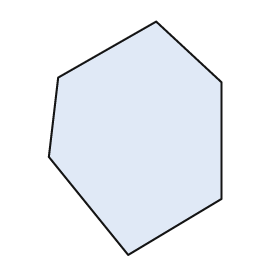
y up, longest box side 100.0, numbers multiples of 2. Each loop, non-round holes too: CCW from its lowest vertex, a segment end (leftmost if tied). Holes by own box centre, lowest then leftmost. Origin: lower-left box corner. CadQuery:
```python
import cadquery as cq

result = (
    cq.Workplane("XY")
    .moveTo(34.0, 0.0)
    .lineTo(74.0, 24.0)
    .lineTo(74.0, 74.0)
    .lineTo(46.0, 100.0)
    .lineTo(4.0, 76.0)
    .lineTo(0.0, 42.0)
    .close()
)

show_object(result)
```